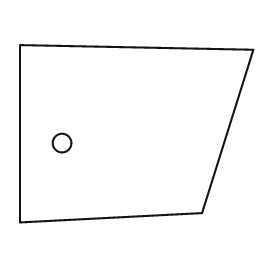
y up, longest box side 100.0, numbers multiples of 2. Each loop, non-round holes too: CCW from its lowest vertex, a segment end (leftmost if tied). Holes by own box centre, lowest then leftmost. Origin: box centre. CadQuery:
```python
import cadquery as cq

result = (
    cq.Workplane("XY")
    .moveTo(-50.0, -38.0)
    .lineTo(28.0, -34.0)
    .lineTo(50.0, 36.0)
    .lineTo(-50.0, 38.0)
    .close()
    .moveTo(-32.0, -4.0)
    .circle(4.0)
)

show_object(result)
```